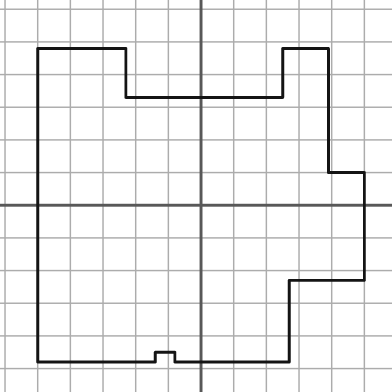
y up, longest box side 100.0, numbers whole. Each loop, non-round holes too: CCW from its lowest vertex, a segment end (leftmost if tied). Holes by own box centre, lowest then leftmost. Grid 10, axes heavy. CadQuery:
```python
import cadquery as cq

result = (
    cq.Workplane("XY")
    .moveTo(-50.0, -48.0)
    .lineTo(-14.0, -48.0)
    .lineTo(-14.0, -45.0)
    .lineTo(-8.0, -45.0)
    .lineTo(-8.0, -48.0)
    .lineTo(27.0, -48.0)
    .lineTo(27.0, -23.0)
    .lineTo(50.0, -23.0)
    .lineTo(50.0, 10.0)
    .lineTo(39.0, 10.0)
    .lineTo(39.0, 48.0)
    .lineTo(25.0, 48.0)
    .lineTo(25.0, 33.0)
    .lineTo(-23.0, 33.0)
    .lineTo(-23.0, 48.0)
    .lineTo(-50.0, 48.0)
    .close()
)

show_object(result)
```